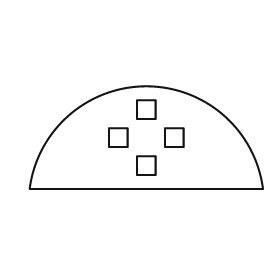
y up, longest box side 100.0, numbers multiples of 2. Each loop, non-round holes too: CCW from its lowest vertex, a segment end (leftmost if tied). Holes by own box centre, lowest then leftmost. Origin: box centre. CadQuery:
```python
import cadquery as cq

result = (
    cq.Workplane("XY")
    .moveTo(-50.0, -22.0)
    .lineTo(50.0, -22.0)
    .threePointArc((0.0, 22.0), (-50.0, -22.0))
    .close()
    .moveTo(-4.0, -16.0)
    .lineTo(4.0, -16.0)
    .lineTo(4.0, -8.0)
    .lineTo(-4.0, -8.0)
    .close()
    .moveTo(-16.0, -4.0)
    .lineTo(-8.0, -4.0)
    .lineTo(-8.0, 4.0)
    .lineTo(-16.0, 4.0)
    .close()
    .moveTo(8.0, -4.0)
    .lineTo(16.0, -4.0)
    .lineTo(16.0, 4.0)
    .lineTo(8.0, 4.0)
    .close()
    .moveTo(-4.0, 8.0)
    .lineTo(4.0, 8.0)
    .lineTo(4.0, 16.0)
    .lineTo(-4.0, 16.0)
    .close()
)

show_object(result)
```